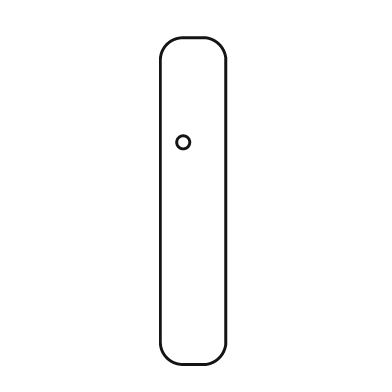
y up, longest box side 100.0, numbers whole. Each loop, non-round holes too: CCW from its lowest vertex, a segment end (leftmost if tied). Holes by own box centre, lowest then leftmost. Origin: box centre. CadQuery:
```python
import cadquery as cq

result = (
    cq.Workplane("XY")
    .moveTo(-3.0, -50.0)
    .lineTo(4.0, -50.0)
    .threePointArc((8.0, -48.0), (10.0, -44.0))
    .lineTo(10.0, 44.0)
    .threePointArc((8.0, 48.0), (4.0, 50.0))
    .lineTo(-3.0, 50.0)
    .threePointArc((-8.0, 48.0), (-10.0, 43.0))
    .lineTo(-10.0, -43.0)
    .threePointArc((-8.0, -48.0), (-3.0, -50.0))
    .close()
    .moveTo(-3.0, 18.0)
    .circle(2.0)
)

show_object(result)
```